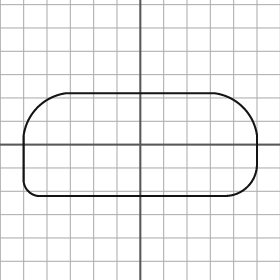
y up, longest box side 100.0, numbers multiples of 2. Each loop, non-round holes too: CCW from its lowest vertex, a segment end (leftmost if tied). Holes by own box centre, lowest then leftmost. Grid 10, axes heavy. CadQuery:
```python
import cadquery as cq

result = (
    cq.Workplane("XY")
    .moveTo(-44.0, -22.0)
    .lineTo(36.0, -22.0)
    .threePointArc((46.0, -18.0), (50.0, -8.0))
    .lineTo(50.0, 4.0)
    .threePointArc((44.0, 16.0), (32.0, 22.0))
    .lineTo(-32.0, 22.0)
    .threePointArc((-44.0, 16.0), (-50.0, 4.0))
    .lineTo(-50.0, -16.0)
    .threePointArc((-48.0, -20.0), (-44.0, -22.0))
    .close()
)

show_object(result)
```